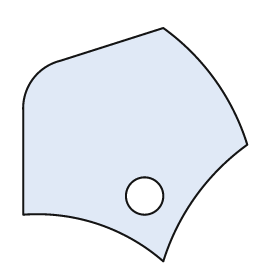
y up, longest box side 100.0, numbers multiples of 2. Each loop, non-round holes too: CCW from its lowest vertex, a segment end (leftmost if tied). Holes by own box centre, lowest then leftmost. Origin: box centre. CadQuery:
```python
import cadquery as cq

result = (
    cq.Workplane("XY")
    .moveTo(12.0, -50.0)
    .threePointArc((26.0, -22.0), (48.0, 0.0))
    .threePointArc((34.0, 28.0), (12.0, 50.0))
    .lineTo(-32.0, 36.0)
    .threePointArc((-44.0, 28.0), (-48.0, 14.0))
    .lineTo(-48.0, -30.0)
    .threePointArc((-16.0, -34.0), (12.0, -50.0))
    .close()
    .moveTo(4.0, -22.0)
    .circle(8.0)
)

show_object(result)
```